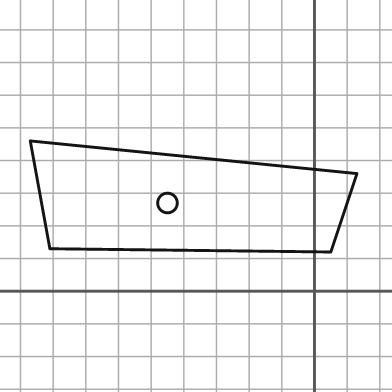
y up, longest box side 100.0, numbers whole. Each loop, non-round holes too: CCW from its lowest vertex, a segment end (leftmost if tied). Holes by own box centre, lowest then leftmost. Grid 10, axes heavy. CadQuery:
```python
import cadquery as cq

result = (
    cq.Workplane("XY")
    .moveTo(5.0, 12.0)
    .lineTo(13.0, 36.0)
    .lineTo(-87.0, 46.0)
    .lineTo(-81.0, 13.0)
    .close()
    .moveTo(-45.0, 27.0)
    .circle(3.0)
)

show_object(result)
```